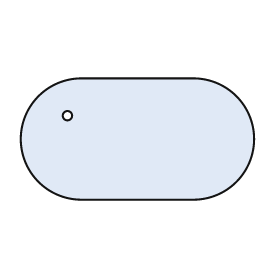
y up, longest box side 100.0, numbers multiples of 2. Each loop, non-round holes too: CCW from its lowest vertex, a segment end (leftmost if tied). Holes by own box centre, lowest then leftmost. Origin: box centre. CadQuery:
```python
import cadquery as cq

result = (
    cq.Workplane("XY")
    .moveTo(-24.0, -26.0)
    .lineTo(24.0, -26.0)
    .threePointArc((50.0, 0.0), (24.0, 26.0))
    .lineTo(-24.0, 26.0)
    .threePointArc((-50.0, 0.0), (-24.0, -26.0))
    .close()
    .moveTo(-30.0, 10.0)
    .circle(2.0)
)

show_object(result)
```